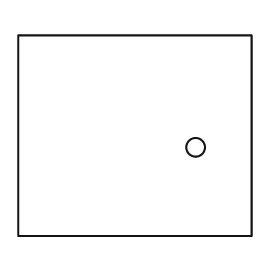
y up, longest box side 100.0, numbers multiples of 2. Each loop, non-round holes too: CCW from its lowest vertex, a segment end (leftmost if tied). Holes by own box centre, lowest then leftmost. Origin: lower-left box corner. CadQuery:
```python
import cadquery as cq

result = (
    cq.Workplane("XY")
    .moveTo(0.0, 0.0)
    .lineTo(100.0, 0.0)
    .lineTo(100.0, 86.0)
    .lineTo(0.0, 86.0)
    .close()
    .moveTo(76.0, 38.0)
    .circle(4.0)
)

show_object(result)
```